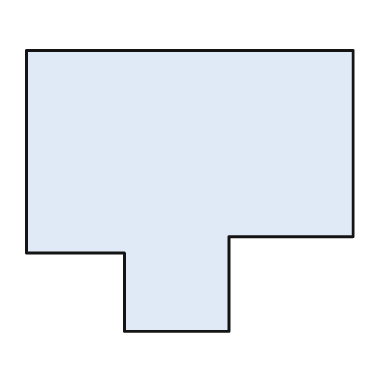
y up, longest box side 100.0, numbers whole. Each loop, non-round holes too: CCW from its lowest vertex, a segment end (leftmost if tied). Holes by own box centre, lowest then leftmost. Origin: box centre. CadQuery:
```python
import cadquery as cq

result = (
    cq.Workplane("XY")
    .moveTo(-20.0, -43.0)
    .lineTo(12.0, -43.0)
    .lineTo(12.0, -14.0)
    .lineTo(50.0, -14.0)
    .lineTo(50.0, 43.0)
    .lineTo(-50.0, 43.0)
    .lineTo(-50.0, -19.0)
    .lineTo(-20.0, -19.0)
    .close()
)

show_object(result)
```